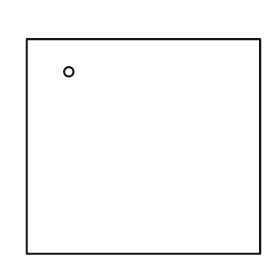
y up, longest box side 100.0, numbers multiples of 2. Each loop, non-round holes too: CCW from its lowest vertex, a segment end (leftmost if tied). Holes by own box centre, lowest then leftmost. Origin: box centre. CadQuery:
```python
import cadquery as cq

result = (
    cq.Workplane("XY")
    .moveTo(-50.0, -46.0)
    .lineTo(50.0, -46.0)
    .lineTo(50.0, 46.0)
    .lineTo(-50.0, 46.0)
    .close()
    .moveTo(-32.0, 32.0)
    .circle(2.0)
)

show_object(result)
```